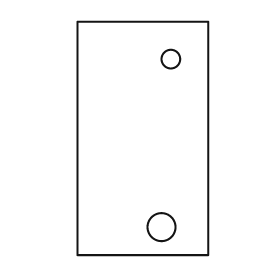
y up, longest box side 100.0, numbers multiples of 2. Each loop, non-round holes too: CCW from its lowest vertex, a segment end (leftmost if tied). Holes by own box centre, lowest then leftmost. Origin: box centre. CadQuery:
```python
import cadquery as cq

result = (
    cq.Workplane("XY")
    .moveTo(-28.0, -50.0)
    .lineTo(28.0, -50.0)
    .lineTo(28.0, 50.0)
    .lineTo(-28.0, 50.0)
    .close()
    .moveTo(8.0, -38.0)
    .circle(6.0)
    .moveTo(12.0, 34.0)
    .circle(4.0)
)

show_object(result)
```